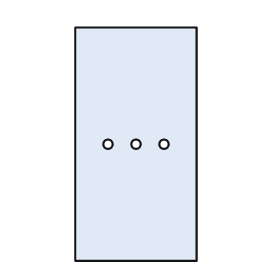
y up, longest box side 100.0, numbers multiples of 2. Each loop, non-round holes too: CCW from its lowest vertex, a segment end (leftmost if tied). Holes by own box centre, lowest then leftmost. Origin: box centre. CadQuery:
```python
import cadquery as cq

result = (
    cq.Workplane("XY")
    .moveTo(-26.0, -50.0)
    .lineTo(26.0, -50.0)
    .lineTo(26.0, 50.0)
    .lineTo(-26.0, 50.0)
    .close()
    .moveTo(-12.0, 0.0)
    .circle(2.0)
    .moveTo(0.0, 0.0)
    .circle(2.0)
    .moveTo(12.0, 0.0)
    .circle(2.0)
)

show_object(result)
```